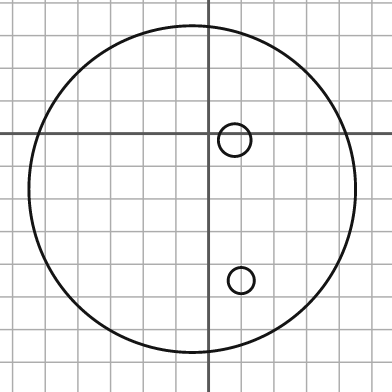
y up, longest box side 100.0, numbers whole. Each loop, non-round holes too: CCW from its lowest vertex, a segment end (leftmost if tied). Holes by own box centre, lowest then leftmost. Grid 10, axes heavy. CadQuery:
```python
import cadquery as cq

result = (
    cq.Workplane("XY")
    .moveTo(-5.0, -17.0)
    .circle(50.0)
    .moveTo(10.0, -45.0)
    .circle(4.0)
    .moveTo(8.0, -2.0)
    .circle(5.0)
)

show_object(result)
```